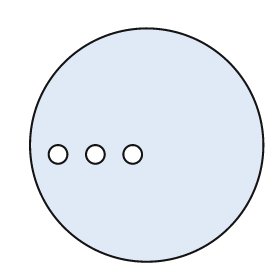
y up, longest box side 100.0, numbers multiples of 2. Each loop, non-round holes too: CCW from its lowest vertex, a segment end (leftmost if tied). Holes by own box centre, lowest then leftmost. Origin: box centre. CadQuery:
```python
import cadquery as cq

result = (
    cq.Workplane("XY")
    .moveTo(0.0, 0.0)
    .circle(50.0)
    .moveTo(-38.0, -4.0)
    .circle(4.0)
    .moveTo(-22.0, -4.0)
    .circle(4.0)
    .moveTo(-6.0, -4.0)
    .circle(4.0)
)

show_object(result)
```